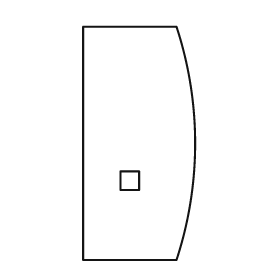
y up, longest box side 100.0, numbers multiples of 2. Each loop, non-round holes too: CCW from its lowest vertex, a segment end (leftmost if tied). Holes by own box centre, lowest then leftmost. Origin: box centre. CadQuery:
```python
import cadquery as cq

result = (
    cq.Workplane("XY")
    .moveTo(-24.0, -50.0)
    .lineTo(16.0, -50.0)
    .threePointArc((24.0, 0.0), (16.0, 50.0))
    .lineTo(-24.0, 50.0)
    .close()
    .moveTo(-8.0, -20.0)
    .lineTo(0.0, -20.0)
    .lineTo(0.0, -12.0)
    .lineTo(-8.0, -12.0)
    .close()
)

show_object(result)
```